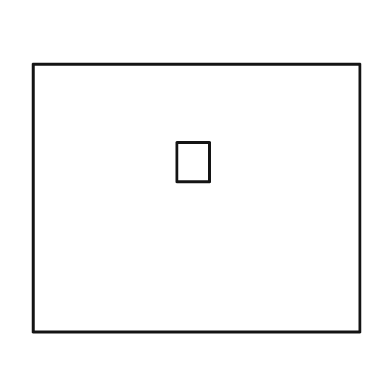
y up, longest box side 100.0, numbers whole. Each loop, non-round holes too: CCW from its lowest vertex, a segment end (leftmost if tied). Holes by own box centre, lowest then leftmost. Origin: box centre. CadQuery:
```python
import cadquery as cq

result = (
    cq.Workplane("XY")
    .moveTo(-50.0, -41.0)
    .lineTo(50.0, -41.0)
    .lineTo(50.0, 41.0)
    .lineTo(-50.0, 41.0)
    .close()
    .moveTo(-6.0, 5.0)
    .lineTo(4.0, 5.0)
    .lineTo(4.0, 17.0)
    .lineTo(-6.0, 17.0)
    .close()
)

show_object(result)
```